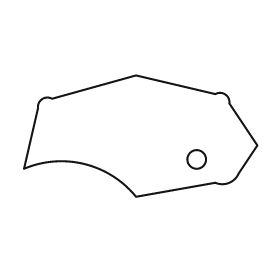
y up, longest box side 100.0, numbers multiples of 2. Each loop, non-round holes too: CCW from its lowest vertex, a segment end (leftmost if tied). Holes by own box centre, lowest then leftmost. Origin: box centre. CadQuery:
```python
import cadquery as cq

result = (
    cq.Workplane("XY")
    .moveTo(-2.0, -26.0)
    .lineTo(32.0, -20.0)
    .threePointArc((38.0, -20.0), (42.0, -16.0))
    .lineTo(50.0, -4.0)
    .lineTo(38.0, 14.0)
    .threePointArc((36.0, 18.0), (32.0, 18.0))
    .lineTo(-2.0, 26.0)
    .lineTo(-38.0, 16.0)
    .threePointArc((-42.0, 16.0), (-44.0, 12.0))
    .lineTo(-50.0, -14.0)
    .threePointArc((-24.0, -12.0), (-2.0, -26.0))
    .close()
    .moveTo(24.0, -10.0)
    .circle(4.0)
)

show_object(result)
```